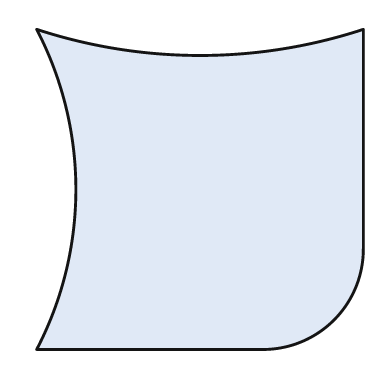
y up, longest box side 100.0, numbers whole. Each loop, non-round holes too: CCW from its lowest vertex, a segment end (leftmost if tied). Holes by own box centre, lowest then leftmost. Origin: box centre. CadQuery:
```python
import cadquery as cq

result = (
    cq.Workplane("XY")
    .moveTo(-50.0, -49.0)
    .lineTo(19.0, -49.0)
    .threePointArc((41.0, -40.0), (50.0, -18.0))
    .lineTo(50.0, 49.0)
    .threePointArc((0.0, 41.0), (-50.0, 49.0))
    .threePointArc((-38.0, 0.0), (-50.0, -49.0))
    .close()
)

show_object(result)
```